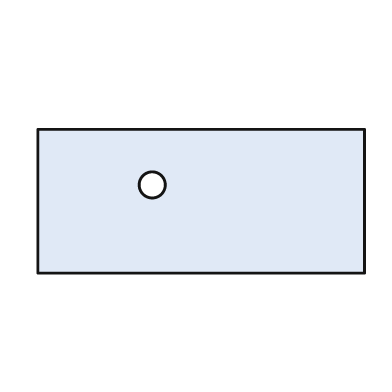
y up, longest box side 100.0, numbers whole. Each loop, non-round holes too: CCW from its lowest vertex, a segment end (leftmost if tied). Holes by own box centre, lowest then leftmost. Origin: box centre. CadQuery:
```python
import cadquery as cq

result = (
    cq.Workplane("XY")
    .moveTo(-50.0, -22.0)
    .lineTo(50.0, -22.0)
    .lineTo(50.0, 22.0)
    .lineTo(-50.0, 22.0)
    .close()
    .moveTo(-15.0, 5.0)
    .circle(4.0)
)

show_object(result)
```